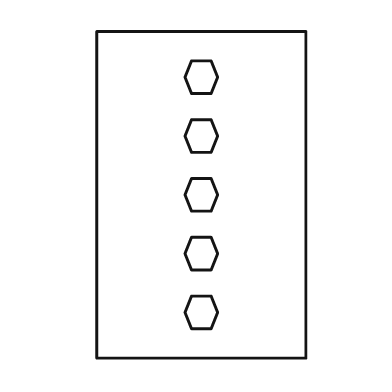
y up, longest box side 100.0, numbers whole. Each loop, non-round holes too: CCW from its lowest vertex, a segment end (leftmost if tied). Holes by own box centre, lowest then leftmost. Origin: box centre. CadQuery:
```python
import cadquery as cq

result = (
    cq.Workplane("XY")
    .moveTo(-32.0, -50.0)
    .lineTo(32.0, -50.0)
    .lineTo(32.0, 50.0)
    .lineTo(-32.0, 50.0)
    .close()
    .moveTo(-3.0, -41.0)
    .lineTo(3.0, -41.0)
    .lineTo(5.0, -36.0)
    .lineTo(3.0, -31.0)
    .lineTo(-3.0, -31.0)
    .lineTo(-5.0, -36.0)
    .close()
    .moveTo(-3.0, -23.0)
    .lineTo(3.0, -23.0)
    .lineTo(5.0, -18.0)
    .lineTo(3.0, -13.0)
    .lineTo(-3.0, -13.0)
    .lineTo(-5.0, -18.0)
    .close()
    .moveTo(-3.0, -5.0)
    .lineTo(3.0, -5.0)
    .lineTo(5.0, 0.0)
    .lineTo(3.0, 5.0)
    .lineTo(-3.0, 5.0)
    .lineTo(-5.0, 0.0)
    .close()
    .moveTo(-3.0, 13.0)
    .lineTo(3.0, 13.0)
    .lineTo(5.0, 18.0)
    .lineTo(3.0, 23.0)
    .lineTo(-3.0, 23.0)
    .lineTo(-5.0, 18.0)
    .close()
    .moveTo(-3.0, 31.0)
    .lineTo(3.0, 31.0)
    .lineTo(5.0, 36.0)
    .lineTo(3.0, 41.0)
    .lineTo(-3.0, 41.0)
    .lineTo(-5.0, 36.0)
    .close()
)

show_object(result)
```